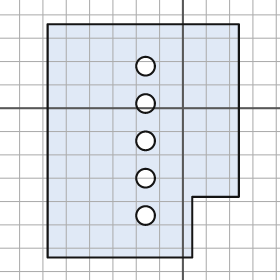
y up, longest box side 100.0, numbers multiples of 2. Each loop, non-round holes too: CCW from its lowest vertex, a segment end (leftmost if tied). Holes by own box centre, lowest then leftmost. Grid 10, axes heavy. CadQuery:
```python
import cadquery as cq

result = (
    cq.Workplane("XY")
    .moveTo(-58.0, -64.0)
    .lineTo(4.0, -64.0)
    .lineTo(4.0, -38.0)
    .lineTo(24.0, -38.0)
    .lineTo(24.0, 36.0)
    .lineTo(-58.0, 36.0)
    .close()
    .moveTo(-16.0, -46.0)
    .circle(4.0)
    .moveTo(-16.0, -30.0)
    .circle(4.0)
    .moveTo(-16.0, -14.0)
    .circle(4.0)
    .moveTo(-16.0, 2.0)
    .circle(4.0)
    .moveTo(-16.0, 18.0)
    .circle(4.0)
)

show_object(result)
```